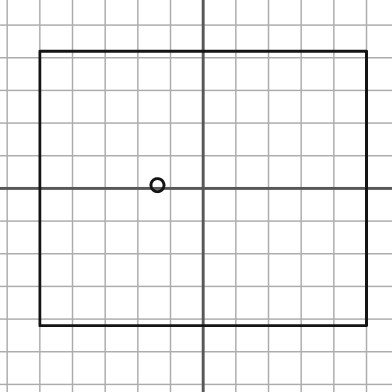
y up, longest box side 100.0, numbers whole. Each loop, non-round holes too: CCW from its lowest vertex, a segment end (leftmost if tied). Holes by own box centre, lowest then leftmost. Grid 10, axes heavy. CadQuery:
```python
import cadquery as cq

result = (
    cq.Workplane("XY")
    .moveTo(-50.0, -42.0)
    .lineTo(50.0, -42.0)
    .lineTo(50.0, 42.0)
    .lineTo(-50.0, 42.0)
    .close()
    .moveTo(-14.0, 1.0)
    .circle(2.0)
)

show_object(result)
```